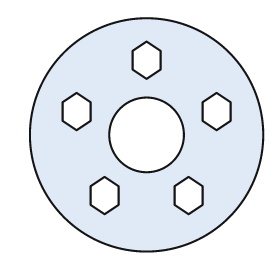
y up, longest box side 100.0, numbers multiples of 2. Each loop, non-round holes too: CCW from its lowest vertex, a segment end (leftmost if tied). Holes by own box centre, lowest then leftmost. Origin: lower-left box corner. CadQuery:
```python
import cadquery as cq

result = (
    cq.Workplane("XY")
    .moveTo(50.0, 50.0)
    .circle(50.0)
    .moveTo(32.0, 16.0)
    .lineTo(38.0, 20.0)
    .lineTo(38.0, 28.0)
    .lineTo(32.0, 32.0)
    .lineTo(26.0, 28.0)
    .lineTo(26.0, 20.0)
    .close()
    .moveTo(68.0, 16.0)
    .lineTo(74.0, 20.0)
    .lineTo(74.0, 28.0)
    .lineTo(68.0, 32.0)
    .lineTo(62.0, 28.0)
    .lineTo(62.0, 20.0)
    .close()
    .moveTo(50.0, 50.0)
    .circle(16.0)
    .moveTo(20.0, 52.0)
    .lineTo(26.0, 56.0)
    .lineTo(26.0, 64.0)
    .lineTo(20.0, 68.0)
    .lineTo(14.0, 64.0)
    .lineTo(14.0, 56.0)
    .close()
    .moveTo(80.0, 52.0)
    .lineTo(86.0, 56.0)
    .lineTo(86.0, 64.0)
    .lineTo(80.0, 68.0)
    .lineTo(74.0, 64.0)
    .lineTo(74.0, 56.0)
    .close()
    .moveTo(50.0, 74.0)
    .lineTo(56.0, 78.0)
    .lineTo(56.0, 86.0)
    .lineTo(50.0, 90.0)
    .lineTo(44.0, 86.0)
    .lineTo(44.0, 78.0)
    .close()
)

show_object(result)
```